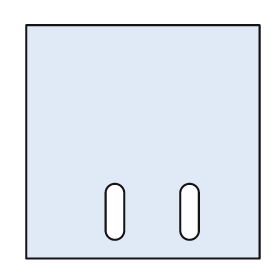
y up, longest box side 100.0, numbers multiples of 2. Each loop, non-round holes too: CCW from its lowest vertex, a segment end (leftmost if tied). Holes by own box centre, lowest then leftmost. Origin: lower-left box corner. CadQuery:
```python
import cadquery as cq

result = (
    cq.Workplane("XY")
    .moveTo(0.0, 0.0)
    .lineTo(100.0, 0.0)
    .lineTo(100.0, 100.0)
    .lineTo(0.0, 100.0)
    .close()
    .moveTo(34.0, 12.0)
    .threePointArc((38.0, 8.0), (42.0, 12.0))
    .lineTo(42.0, 28.0)
    .threePointArc((38.0, 32.0), (34.0, 28.0))
    .close()
    .moveTo(66.0, 12.0)
    .threePointArc((70.0, 8.0), (74.0, 12.0))
    .lineTo(74.0, 28.0)
    .threePointArc((70.0, 32.0), (66.0, 28.0))
    .close()
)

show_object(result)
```